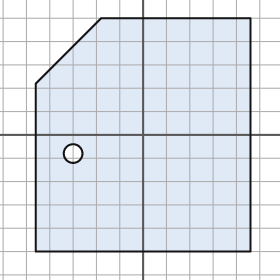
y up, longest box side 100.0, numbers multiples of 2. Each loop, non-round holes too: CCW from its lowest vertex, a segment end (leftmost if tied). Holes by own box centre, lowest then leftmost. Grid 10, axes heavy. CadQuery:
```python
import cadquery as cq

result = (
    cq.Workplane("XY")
    .moveTo(-46.0, -50.0)
    .lineTo(46.0, -50.0)
    .lineTo(46.0, 50.0)
    .lineTo(-18.0, 50.0)
    .lineTo(-46.0, 22.0)
    .close()
    .moveTo(-30.0, -8.0)
    .circle(4.0)
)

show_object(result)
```